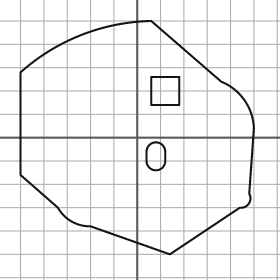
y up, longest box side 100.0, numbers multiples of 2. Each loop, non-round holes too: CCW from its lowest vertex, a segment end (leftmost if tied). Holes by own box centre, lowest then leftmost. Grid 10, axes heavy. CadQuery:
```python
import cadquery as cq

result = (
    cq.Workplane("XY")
    .moveTo(14.0, -50.0)
    .lineTo(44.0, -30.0)
    .threePointArc((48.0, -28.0), (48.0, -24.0))
    .lineTo(50.0, 4.0)
    .threePointArc((46.0, 16.0), (36.0, 24.0))
    .lineTo(6.0, 50.0)
    .threePointArc((-24.0, 44.0), (-50.0, 28.0))
    .lineTo(-50.0, -16.0)
    .lineTo(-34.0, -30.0)
    .threePointArc((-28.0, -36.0), (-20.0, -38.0))
    .close()
    .moveTo(4.0, -10.0)
    .threePointArc((8.0, -14.0), (12.0, -10.0))
    .lineTo(12.0, -6.0)
    .threePointArc((8.0, -2.0), (4.0, -6.0))
    .close()
    .moveTo(6.0, 14.0)
    .lineTo(18.0, 14.0)
    .lineTo(18.0, 26.0)
    .lineTo(6.0, 26.0)
    .close()
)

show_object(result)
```